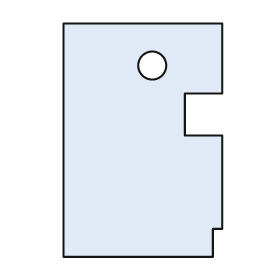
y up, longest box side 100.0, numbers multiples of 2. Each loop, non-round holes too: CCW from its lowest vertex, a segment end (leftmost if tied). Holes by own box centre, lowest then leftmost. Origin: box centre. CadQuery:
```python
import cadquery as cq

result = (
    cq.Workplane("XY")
    .moveTo(-34.0, -50.0)
    .lineTo(30.0, -50.0)
    .lineTo(30.0, -38.0)
    .lineTo(34.0, -38.0)
    .lineTo(34.0, 2.0)
    .lineTo(18.0, 2.0)
    .lineTo(18.0, 20.0)
    .lineTo(34.0, 20.0)
    .lineTo(34.0, 50.0)
    .lineTo(-34.0, 50.0)
    .close()
    .moveTo(4.0, 32.0)
    .circle(6.0)
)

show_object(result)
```